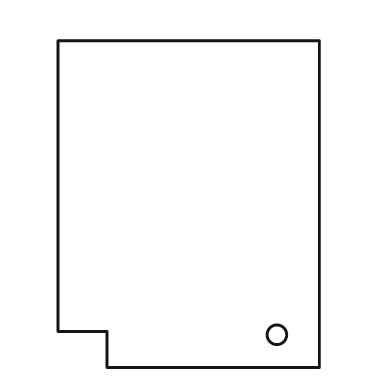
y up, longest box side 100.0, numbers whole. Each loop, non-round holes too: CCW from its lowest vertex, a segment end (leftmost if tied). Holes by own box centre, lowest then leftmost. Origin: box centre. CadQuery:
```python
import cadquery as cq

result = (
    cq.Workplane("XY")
    .moveTo(-25.0, -50.0)
    .lineTo(40.0, -50.0)
    .lineTo(40.0, 50.0)
    .lineTo(-40.0, 50.0)
    .lineTo(-40.0, -39.0)
    .lineTo(-25.0, -39.0)
    .close()
    .moveTo(27.0, -40.0)
    .circle(3.0)
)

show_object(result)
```